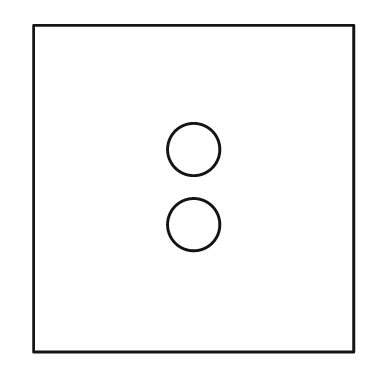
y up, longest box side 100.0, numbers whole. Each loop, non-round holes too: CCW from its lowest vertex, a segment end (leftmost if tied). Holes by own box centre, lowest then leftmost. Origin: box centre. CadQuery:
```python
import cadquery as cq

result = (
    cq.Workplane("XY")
    .moveTo(-49.0, -50.0)
    .lineTo(49.0, -50.0)
    .lineTo(49.0, 50.0)
    .lineTo(-49.0, 50.0)
    .close()
    .moveTo(0.0, -11.0)
    .circle(8.0)
    .moveTo(0.0, 12.0)
    .circle(8.0)
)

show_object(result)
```